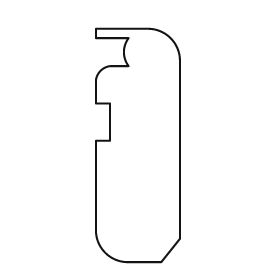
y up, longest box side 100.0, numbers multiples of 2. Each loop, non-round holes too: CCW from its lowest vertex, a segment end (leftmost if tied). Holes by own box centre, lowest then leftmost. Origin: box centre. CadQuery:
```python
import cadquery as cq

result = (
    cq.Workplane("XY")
    .moveTo(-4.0, -50.0)
    .lineTo(10.0, -50.0)
    .lineTo(18.0, -40.0)
    .lineTo(18.0, 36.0)
    .threePointArc((14.0, 46.0), (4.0, 50.0))
    .lineTo(-18.0, 50.0)
    .lineTo(-18.0, 46.0)
    .lineTo(-4.0, 46.0)
    .threePointArc((-6.0, 40.0), (-4.0, 34.0))
    .lineTo(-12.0, 34.0)
    .threePointArc((-16.0, 32.0), (-18.0, 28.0))
    .lineTo(-18.0, 18.0)
    .lineTo(-12.0, 18.0)
    .lineTo(-12.0, 2.0)
    .lineTo(-18.0, 2.0)
    .lineTo(-18.0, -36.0)
    .threePointArc((-14.0, -46.0), (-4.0, -50.0))
    .close()
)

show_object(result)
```